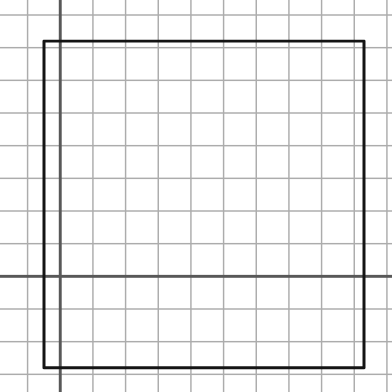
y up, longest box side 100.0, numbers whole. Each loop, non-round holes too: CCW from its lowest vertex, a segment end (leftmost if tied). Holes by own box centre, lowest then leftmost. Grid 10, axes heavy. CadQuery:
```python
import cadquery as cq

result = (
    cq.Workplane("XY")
    .moveTo(-5.0, -28.0)
    .lineTo(93.0, -28.0)
    .lineTo(93.0, 72.0)
    .lineTo(-5.0, 72.0)
    .close()
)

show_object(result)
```